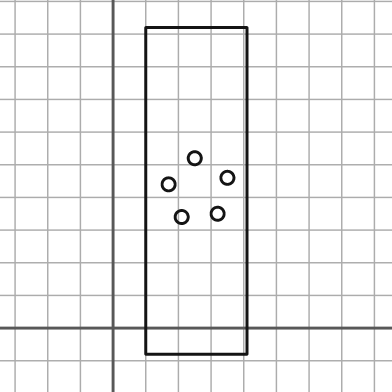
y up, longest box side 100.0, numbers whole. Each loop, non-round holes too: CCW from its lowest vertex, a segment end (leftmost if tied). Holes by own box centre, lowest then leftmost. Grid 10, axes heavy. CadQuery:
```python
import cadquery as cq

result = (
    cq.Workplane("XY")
    .moveTo(10.0, -8.0)
    .lineTo(41.0, -8.0)
    .lineTo(41.0, 92.0)
    .lineTo(10.0, 92.0)
    .close()
    .moveTo(21.0, 34.0)
    .circle(2.0)
    .moveTo(32.0, 35.0)
    .circle(2.0)
    .moveTo(17.0, 44.0)
    .circle(2.0)
    .moveTo(35.0, 46.0)
    .circle(2.0)
    .moveTo(25.0, 52.0)
    .circle(2.0)
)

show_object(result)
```